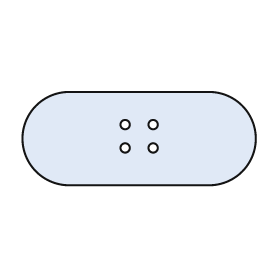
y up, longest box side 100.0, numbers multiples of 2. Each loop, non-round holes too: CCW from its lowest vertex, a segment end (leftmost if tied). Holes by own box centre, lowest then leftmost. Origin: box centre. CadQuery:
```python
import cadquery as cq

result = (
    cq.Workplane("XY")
    .moveTo(-30.0, -20.0)
    .lineTo(30.0, -20.0)
    .threePointArc((50.0, 0.0), (30.0, 20.0))
    .lineTo(-30.0, 20.0)
    .threePointArc((-50.0, 0.0), (-30.0, -20.0))
    .close()
    .moveTo(-6.0, -4.0)
    .circle(2.0)
    .moveTo(6.0, -4.0)
    .circle(2.0)
    .moveTo(-6.0, 6.0)
    .circle(2.0)
    .moveTo(6.0, 6.0)
    .circle(2.0)
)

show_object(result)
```